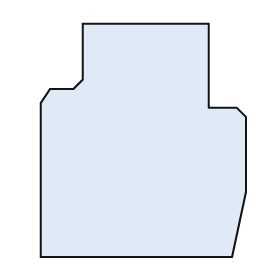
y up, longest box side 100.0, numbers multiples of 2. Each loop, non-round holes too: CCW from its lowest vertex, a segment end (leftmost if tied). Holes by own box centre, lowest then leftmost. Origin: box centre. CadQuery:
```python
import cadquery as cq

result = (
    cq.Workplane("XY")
    .moveTo(-44.0, -50.0)
    .lineTo(38.0, -50.0)
    .lineTo(44.0, -22.0)
    .lineTo(44.0, 10.0)
    .lineTo(40.0, 14.0)
    .lineTo(28.0, 14.0)
    .lineTo(28.0, 50.0)
    .lineTo(-26.0, 50.0)
    .lineTo(-26.0, 26.0)
    .lineTo(-30.0, 22.0)
    .lineTo(-40.0, 22.0)
    .lineTo(-44.0, 16.0)
    .close()
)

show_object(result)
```